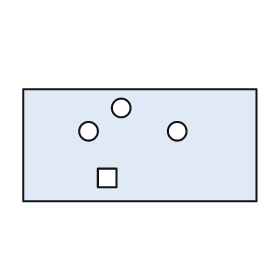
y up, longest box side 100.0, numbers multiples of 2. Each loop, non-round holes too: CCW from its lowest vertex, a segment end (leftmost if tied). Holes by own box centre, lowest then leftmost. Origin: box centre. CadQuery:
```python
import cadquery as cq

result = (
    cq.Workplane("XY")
    .moveTo(-50.0, -24.0)
    .lineTo(50.0, -24.0)
    .lineTo(50.0, 24.0)
    .lineTo(-50.0, 24.0)
    .close()
    .moveTo(-18.0, -18.0)
    .lineTo(-10.0, -18.0)
    .lineTo(-10.0, -10.0)
    .lineTo(-18.0, -10.0)
    .close()
    .moveTo(-22.0, 6.0)
    .circle(4.0)
    .moveTo(16.0, 6.0)
    .circle(4.0)
    .moveTo(-8.0, 16.0)
    .circle(4.0)
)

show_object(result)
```